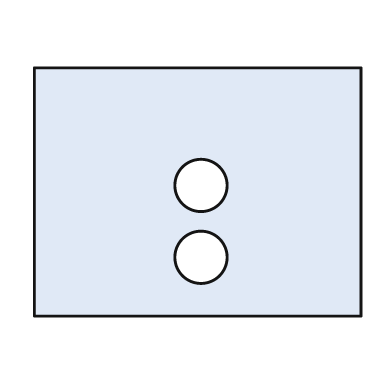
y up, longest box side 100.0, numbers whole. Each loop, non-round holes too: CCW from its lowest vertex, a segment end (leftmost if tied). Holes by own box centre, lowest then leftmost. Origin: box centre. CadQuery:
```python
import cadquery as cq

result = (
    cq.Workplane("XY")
    .moveTo(-50.0, -38.0)
    .lineTo(50.0, -38.0)
    .lineTo(50.0, 38.0)
    .lineTo(-50.0, 38.0)
    .close()
    .moveTo(1.0, -20.0)
    .circle(8.0)
    .moveTo(1.0, 2.0)
    .circle(8.0)
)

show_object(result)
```